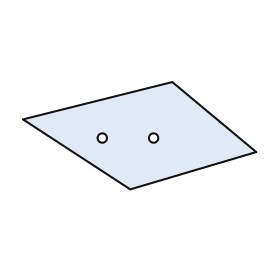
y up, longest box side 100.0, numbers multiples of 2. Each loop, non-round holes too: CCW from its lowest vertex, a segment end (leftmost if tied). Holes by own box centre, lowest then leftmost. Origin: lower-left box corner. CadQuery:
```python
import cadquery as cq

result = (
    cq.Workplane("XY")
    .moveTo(46.0, 0.0)
    .lineTo(100.0, 16.0)
    .lineTo(64.0, 46.0)
    .lineTo(0.0, 30.0)
    .close()
    .moveTo(34.0, 22.0)
    .circle(2.0)
    .moveTo(56.0, 22.0)
    .circle(2.0)
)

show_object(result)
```